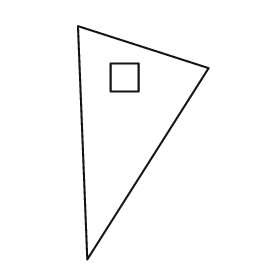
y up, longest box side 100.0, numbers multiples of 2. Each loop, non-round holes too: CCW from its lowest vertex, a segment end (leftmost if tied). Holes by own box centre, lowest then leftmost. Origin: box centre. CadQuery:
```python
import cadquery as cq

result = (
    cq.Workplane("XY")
    .moveTo(-24.0, -50.0)
    .lineTo(28.0, 32.0)
    .lineTo(-28.0, 50.0)
    .close()
    .moveTo(-14.0, 22.0)
    .lineTo(-2.0, 22.0)
    .lineTo(-2.0, 34.0)
    .lineTo(-14.0, 34.0)
    .close()
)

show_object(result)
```